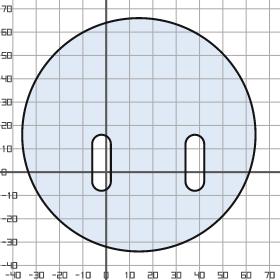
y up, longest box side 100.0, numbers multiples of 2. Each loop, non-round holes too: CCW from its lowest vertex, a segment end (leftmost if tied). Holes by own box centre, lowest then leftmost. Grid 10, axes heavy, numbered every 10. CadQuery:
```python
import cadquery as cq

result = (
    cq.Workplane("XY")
    .moveTo(14.0, 16.0)
    .circle(50.0)
    .moveTo(-6.0, -4.0)
    .threePointArc((-2.0, -8.0), (2.0, -4.0))
    .lineTo(2.0, 12.0)
    .threePointArc((-2.0, 16.0), (-6.0, 12.0))
    .close()
    .moveTo(34.0, -4.0)
    .threePointArc((38.0, -8.0), (42.0, -4.0))
    .lineTo(42.0, 12.0)
    .threePointArc((38.0, 16.0), (34.0, 12.0))
    .close()
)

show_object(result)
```